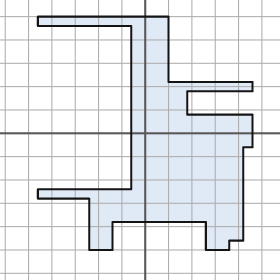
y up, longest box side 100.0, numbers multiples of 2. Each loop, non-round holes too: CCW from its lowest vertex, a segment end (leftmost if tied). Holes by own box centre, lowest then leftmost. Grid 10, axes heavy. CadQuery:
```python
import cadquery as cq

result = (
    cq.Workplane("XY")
    .moveTo(-24.0, -50.0)
    .lineTo(-14.0, -50.0)
    .lineTo(-14.0, -38.0)
    .lineTo(26.0, -38.0)
    .lineTo(26.0, -50.0)
    .lineTo(36.0, -50.0)
    .lineTo(36.0, -46.0)
    .lineTo(42.0, -46.0)
    .lineTo(42.0, -6.0)
    .lineTo(46.0, -6.0)
    .lineTo(46.0, 8.0)
    .lineTo(18.0, 8.0)
    .lineTo(18.0, 18.0)
    .lineTo(46.0, 18.0)
    .lineTo(46.0, 22.0)
    .lineTo(10.0, 22.0)
    .lineTo(10.0, 50.0)
    .lineTo(-46.0, 50.0)
    .lineTo(-46.0, 46.0)
    .lineTo(-6.0, 46.0)
    .lineTo(-6.0, -24.0)
    .lineTo(-46.0, -24.0)
    .lineTo(-46.0, -28.0)
    .lineTo(-24.0, -28.0)
    .close()
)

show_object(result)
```